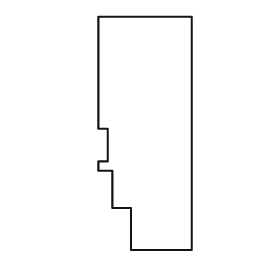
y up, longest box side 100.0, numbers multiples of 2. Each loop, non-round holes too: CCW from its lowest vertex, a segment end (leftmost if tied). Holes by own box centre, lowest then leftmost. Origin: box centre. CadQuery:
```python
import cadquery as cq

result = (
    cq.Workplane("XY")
    .moveTo(-6.0, -50.0)
    .lineTo(20.0, -50.0)
    .lineTo(20.0, 50.0)
    .lineTo(-20.0, 50.0)
    .lineTo(-20.0, 2.0)
    .lineTo(-16.0, 2.0)
    .lineTo(-16.0, -12.0)
    .lineTo(-20.0, -12.0)
    .lineTo(-20.0, -16.0)
    .lineTo(-14.0, -16.0)
    .lineTo(-14.0, -32.0)
    .lineTo(-6.0, -32.0)
    .close()
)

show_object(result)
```